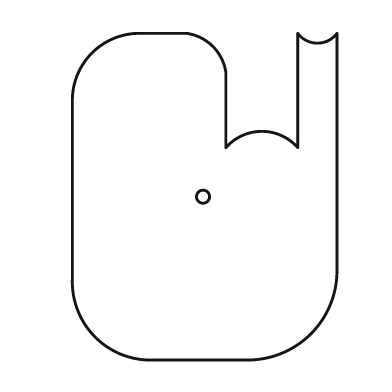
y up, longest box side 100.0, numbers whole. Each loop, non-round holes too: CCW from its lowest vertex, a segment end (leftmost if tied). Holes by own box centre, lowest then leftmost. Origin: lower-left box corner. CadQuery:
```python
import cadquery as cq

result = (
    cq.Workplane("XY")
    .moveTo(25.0, 0.0)
    .lineTo(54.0, 0.0)
    .threePointArc((73.0, 8.0), (81.0, 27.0))
    .lineTo(81.0, 100.0)
    .threePointArc((75.0, 97.0), (69.0, 100.0))
    .lineTo(69.0, 65.0)
    .threePointArc((58.0, 70.0), (47.0, 65.0))
    .lineTo(47.0, 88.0)
    .threePointArc((43.0, 96.0), (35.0, 100.0))
    .lineTo(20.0, 100.0)
    .threePointArc((6.0, 94.0), (0.0, 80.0))
    .lineTo(0.0, 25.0)
    .threePointArc((7.0, 7.0), (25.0, 0.0))
    .close()
    .moveTo(40.0, 50.0)
    .circle(2.0)
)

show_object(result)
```